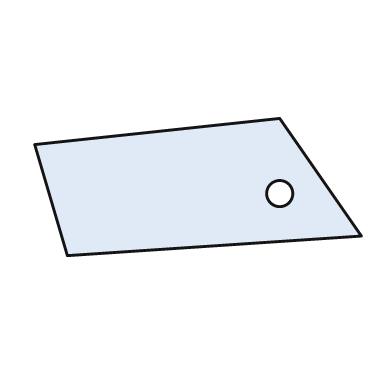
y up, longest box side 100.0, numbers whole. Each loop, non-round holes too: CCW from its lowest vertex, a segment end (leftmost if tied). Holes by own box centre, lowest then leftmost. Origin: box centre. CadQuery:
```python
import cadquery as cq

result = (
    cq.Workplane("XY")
    .moveTo(-40.0, -21.0)
    .lineTo(50.0, -15.0)
    .lineTo(25.0, 21.0)
    .lineTo(-50.0, 13.0)
    .close()
    .moveTo(25.0, -2.0)
    .circle(4.0)
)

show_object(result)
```